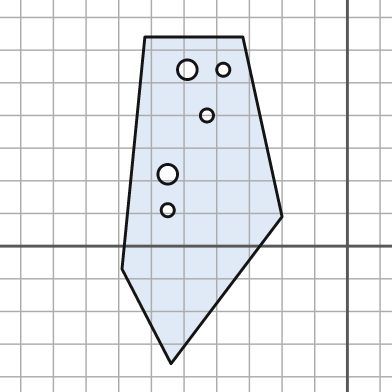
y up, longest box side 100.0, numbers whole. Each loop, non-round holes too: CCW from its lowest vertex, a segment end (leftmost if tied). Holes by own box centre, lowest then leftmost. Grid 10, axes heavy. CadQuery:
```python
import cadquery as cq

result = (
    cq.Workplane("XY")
    .moveTo(-54.0, -36.0)
    .lineTo(-20.0, 9.0)
    .lineTo(-32.0, 64.0)
    .lineTo(-62.0, 64.0)
    .lineTo(-69.0, -7.0)
    .close()
    .moveTo(-55.0, 11.0)
    .circle(2.0)
    .moveTo(-55.0, 22.0)
    .circle(3.0)
    .moveTo(-43.0, 40.0)
    .circle(2.0)
    .moveTo(-49.0, 54.0)
    .circle(3.0)
    .moveTo(-38.0, 54.0)
    .circle(2.0)
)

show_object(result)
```